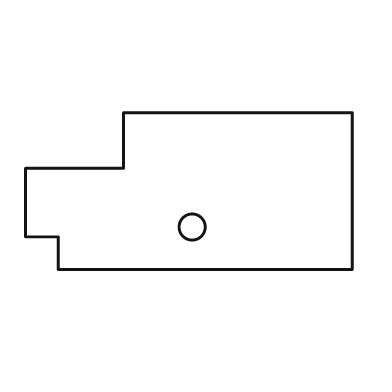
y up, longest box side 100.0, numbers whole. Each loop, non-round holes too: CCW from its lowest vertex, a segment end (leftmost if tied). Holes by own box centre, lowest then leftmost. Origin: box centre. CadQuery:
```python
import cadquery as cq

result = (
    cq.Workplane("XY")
    .moveTo(-40.0, -24.0)
    .lineTo(50.0, -24.0)
    .lineTo(50.0, 24.0)
    .lineTo(-20.0, 24.0)
    .lineTo(-20.0, 7.0)
    .lineTo(-50.0, 7.0)
    .lineTo(-50.0, -14.0)
    .lineTo(-40.0, -14.0)
    .close()
    .moveTo(1.0, -11.0)
    .circle(4.0)
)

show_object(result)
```